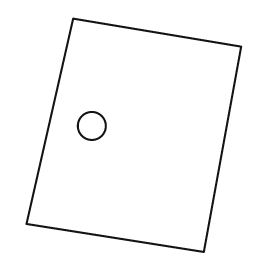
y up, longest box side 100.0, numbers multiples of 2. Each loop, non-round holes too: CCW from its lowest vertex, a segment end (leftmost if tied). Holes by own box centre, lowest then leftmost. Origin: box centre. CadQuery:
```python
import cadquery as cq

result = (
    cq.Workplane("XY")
    .moveTo(30.0, -50.0)
    .lineTo(46.0, 38.0)
    .lineTo(-26.0, 50.0)
    .lineTo(-46.0, -38.0)
    .close()
    .moveTo(-18.0, 4.0)
    .circle(6.0)
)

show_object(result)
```